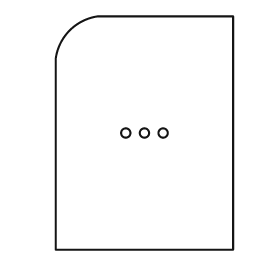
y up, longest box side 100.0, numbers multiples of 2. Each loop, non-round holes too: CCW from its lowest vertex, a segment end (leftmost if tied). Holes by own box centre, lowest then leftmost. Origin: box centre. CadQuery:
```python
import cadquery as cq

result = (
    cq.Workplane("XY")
    .moveTo(-38.0, -50.0)
    .lineTo(38.0, -50.0)
    .lineTo(38.0, 50.0)
    .lineTo(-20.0, 50.0)
    .threePointArc((-32.0, 44.0), (-38.0, 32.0))
    .close()
    .moveTo(-8.0, 0.0)
    .circle(2.0)
    .moveTo(0.0, 0.0)
    .circle(2.0)
    .moveTo(8.0, 0.0)
    .circle(2.0)
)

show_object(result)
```